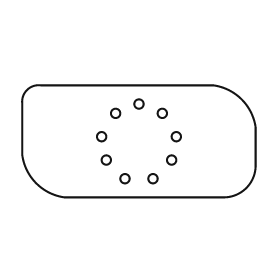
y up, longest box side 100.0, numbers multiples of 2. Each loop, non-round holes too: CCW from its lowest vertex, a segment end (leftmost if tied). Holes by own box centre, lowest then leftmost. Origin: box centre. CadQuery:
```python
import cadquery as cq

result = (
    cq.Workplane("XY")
    .moveTo(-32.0, -24.0)
    .lineTo(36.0, -24.0)
    .threePointArc((46.0, -20.0), (50.0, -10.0))
    .lineTo(50.0, 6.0)
    .threePointArc((44.0, 18.0), (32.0, 24.0))
    .lineTo(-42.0, 24.0)
    .threePointArc((-48.0, 22.0), (-50.0, 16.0))
    .lineTo(-50.0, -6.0)
    .threePointArc((-44.0, -18.0), (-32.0, -24.0))
    .close()
    .moveTo(-6.0, -16.0)
    .circle(2.0)
    .moveTo(6.0, -16.0)
    .circle(2.0)
    .moveTo(-14.0, -8.0)
    .circle(2.0)
    .moveTo(14.0, -8.0)
    .circle(2.0)
    .moveTo(-16.0, 2.0)
    .circle(2.0)
    .moveTo(16.0, 2.0)
    .circle(2.0)
    .moveTo(-10.0, 12.0)
    .circle(2.0)
    .moveTo(10.0, 12.0)
    .circle(2.0)
    .moveTo(0.0, 16.0)
    .circle(2.0)
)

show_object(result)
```